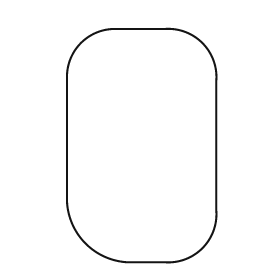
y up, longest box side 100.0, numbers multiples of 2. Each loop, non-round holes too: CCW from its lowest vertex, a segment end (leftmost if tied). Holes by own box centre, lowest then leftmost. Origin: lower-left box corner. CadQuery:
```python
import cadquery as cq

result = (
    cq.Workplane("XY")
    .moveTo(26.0, 0.0)
    .lineTo(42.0, 0.0)
    .threePointArc((58.0, 6.0), (64.0, 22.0))
    .lineTo(64.0, 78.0)
    .threePointArc((58.0, 94.0), (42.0, 100.0))
    .lineTo(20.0, 100.0)
    .threePointArc((6.0, 94.0), (0.0, 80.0))
    .lineTo(0.0, 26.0)
    .threePointArc((8.0, 8.0), (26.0, 0.0))
    .close()
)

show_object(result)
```